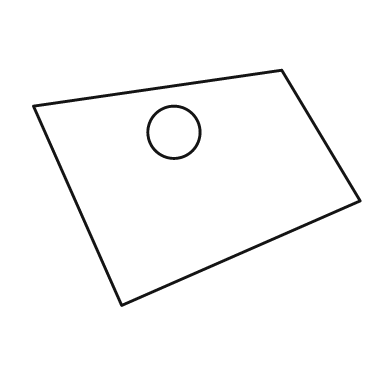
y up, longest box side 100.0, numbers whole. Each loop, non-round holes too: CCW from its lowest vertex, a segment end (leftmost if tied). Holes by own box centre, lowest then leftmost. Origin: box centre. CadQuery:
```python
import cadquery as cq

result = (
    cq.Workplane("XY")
    .moveTo(-23.0, -36.0)
    .lineTo(50.0, -4.0)
    .lineTo(26.0, 36.0)
    .lineTo(-50.0, 25.0)
    .close()
    .moveTo(-7.0, 17.0)
    .circle(8.0)
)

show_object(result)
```